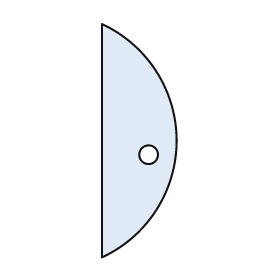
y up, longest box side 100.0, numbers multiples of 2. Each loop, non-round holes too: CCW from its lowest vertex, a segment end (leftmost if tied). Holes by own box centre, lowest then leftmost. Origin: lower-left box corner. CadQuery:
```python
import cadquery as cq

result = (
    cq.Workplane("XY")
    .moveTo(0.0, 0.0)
    .threePointArc((32.0, 50.0), (0.0, 100.0))
    .close()
    .moveTo(20.0, 44.0)
    .circle(4.0)
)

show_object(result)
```